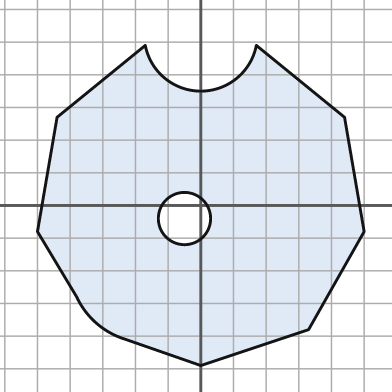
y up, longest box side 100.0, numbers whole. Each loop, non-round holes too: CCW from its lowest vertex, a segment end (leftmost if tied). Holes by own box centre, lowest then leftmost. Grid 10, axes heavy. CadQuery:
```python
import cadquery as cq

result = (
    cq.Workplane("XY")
    .moveTo(0.0, -49.0)
    .lineTo(33.0, -38.0)
    .lineTo(50.0, -8.0)
    .lineTo(44.0, 27.0)
    .lineTo(17.0, 49.0)
    .threePointArc((0.0, 35.0), (-17.0, 49.0))
    .lineTo(-44.0, 27.0)
    .lineTo(-50.0, -8.0)
    .lineTo(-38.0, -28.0)
    .threePointArc((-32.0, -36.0), (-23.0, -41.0))
    .close()
    .moveTo(-5.0, -4.0)
    .circle(8.0)
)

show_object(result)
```